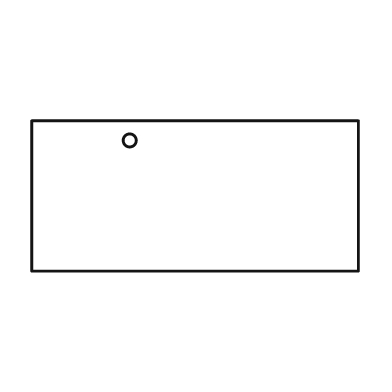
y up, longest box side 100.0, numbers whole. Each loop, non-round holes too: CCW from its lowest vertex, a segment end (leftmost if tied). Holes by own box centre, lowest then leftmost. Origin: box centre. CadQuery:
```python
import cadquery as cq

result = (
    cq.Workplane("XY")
    .moveTo(-50.0, -23.0)
    .lineTo(50.0, -23.0)
    .lineTo(50.0, 23.0)
    .lineTo(-50.0, 23.0)
    .close()
    .moveTo(-20.0, 17.0)
    .circle(2.0)
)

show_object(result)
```